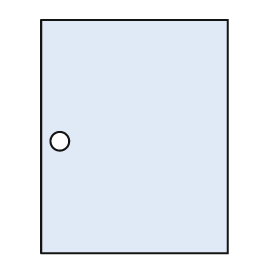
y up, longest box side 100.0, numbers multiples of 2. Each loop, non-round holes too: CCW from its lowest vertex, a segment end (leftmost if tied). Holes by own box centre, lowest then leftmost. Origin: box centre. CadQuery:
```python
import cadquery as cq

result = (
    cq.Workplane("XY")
    .moveTo(-40.0, -50.0)
    .lineTo(40.0, -50.0)
    .lineTo(40.0, 50.0)
    .lineTo(-40.0, 50.0)
    .close()
    .moveTo(-32.0, -2.0)
    .circle(4.0)
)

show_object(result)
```